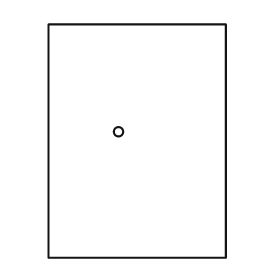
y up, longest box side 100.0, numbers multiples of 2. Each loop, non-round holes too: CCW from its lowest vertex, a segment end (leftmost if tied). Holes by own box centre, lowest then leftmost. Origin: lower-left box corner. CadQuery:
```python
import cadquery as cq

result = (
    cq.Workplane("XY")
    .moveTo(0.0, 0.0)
    .lineTo(76.0, 0.0)
    .lineTo(76.0, 100.0)
    .lineTo(0.0, 100.0)
    .close()
    .moveTo(30.0, 54.0)
    .circle(2.0)
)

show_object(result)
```